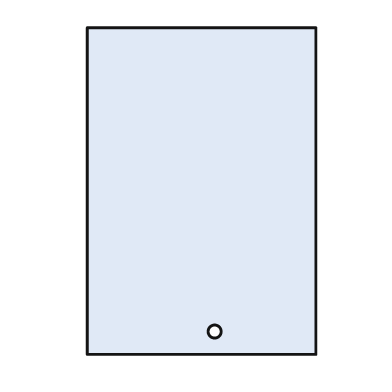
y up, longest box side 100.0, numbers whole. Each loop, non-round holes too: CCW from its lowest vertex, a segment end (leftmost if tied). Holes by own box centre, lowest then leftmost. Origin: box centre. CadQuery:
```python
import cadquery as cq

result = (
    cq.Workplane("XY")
    .moveTo(-35.0, -50.0)
    .lineTo(35.0, -50.0)
    .lineTo(35.0, 50.0)
    .lineTo(-35.0, 50.0)
    .close()
    .moveTo(4.0, -43.0)
    .circle(2.0)
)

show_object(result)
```